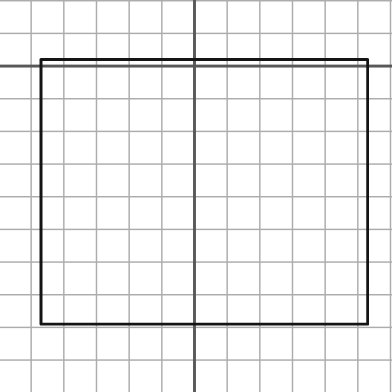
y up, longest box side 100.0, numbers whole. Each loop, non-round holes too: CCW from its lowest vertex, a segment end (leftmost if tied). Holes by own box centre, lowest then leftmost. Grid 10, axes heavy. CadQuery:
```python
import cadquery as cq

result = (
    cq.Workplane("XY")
    .moveTo(-47.0, -79.0)
    .lineTo(53.0, -79.0)
    .lineTo(53.0, 2.0)
    .lineTo(-47.0, 2.0)
    .close()
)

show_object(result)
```